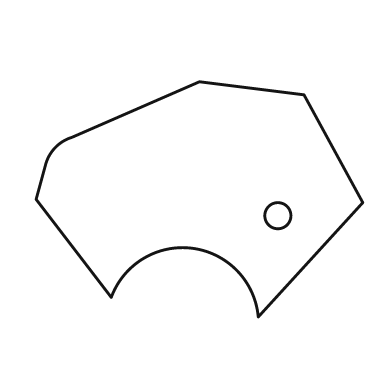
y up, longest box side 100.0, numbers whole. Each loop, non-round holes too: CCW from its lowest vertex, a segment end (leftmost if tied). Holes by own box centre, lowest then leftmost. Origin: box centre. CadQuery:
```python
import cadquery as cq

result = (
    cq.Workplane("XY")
    .moveTo(18.0, -36.0)
    .lineTo(50.0, -1.0)
    .lineTo(32.0, 32.0)
    .lineTo(0.0, 36.0)
    .lineTo(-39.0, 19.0)
    .threePointArc((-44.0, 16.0), (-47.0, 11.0))
    .lineTo(-50.0, 0.0)
    .lineTo(-27.0, -30.0)
    .threePointArc((-2.0, -15.0), (18.0, -36.0))
    .close()
    .moveTo(24.0, -5.0)
    .circle(4.0)
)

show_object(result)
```